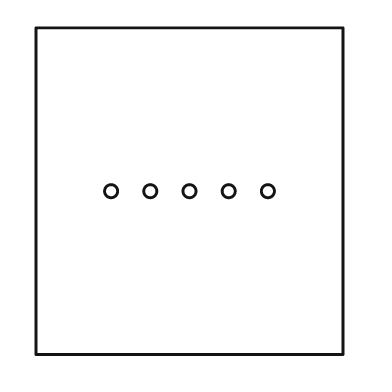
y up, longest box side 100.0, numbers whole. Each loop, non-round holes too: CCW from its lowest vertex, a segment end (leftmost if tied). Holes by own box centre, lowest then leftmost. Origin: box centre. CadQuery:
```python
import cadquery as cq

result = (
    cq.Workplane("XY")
    .moveTo(-47.0, -50.0)
    .lineTo(47.0, -50.0)
    .lineTo(47.0, 50.0)
    .lineTo(-47.0, 50.0)
    .close()
    .moveTo(-24.0, 0.0)
    .circle(2.0)
    .moveTo(-12.0, 0.0)
    .circle(2.0)
    .moveTo(0.0, 0.0)
    .circle(2.0)
    .moveTo(12.0, 0.0)
    .circle(2.0)
    .moveTo(24.0, 0.0)
    .circle(2.0)
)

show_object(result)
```